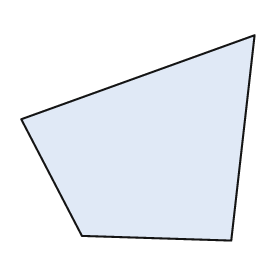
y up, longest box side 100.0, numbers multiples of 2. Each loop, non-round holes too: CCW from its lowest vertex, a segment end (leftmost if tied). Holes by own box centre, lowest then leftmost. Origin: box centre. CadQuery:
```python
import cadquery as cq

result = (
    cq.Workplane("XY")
    .moveTo(40.0, -44.0)
    .lineTo(50.0, 44.0)
    .lineTo(-50.0, 8.0)
    .lineTo(-24.0, -42.0)
    .close()
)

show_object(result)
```